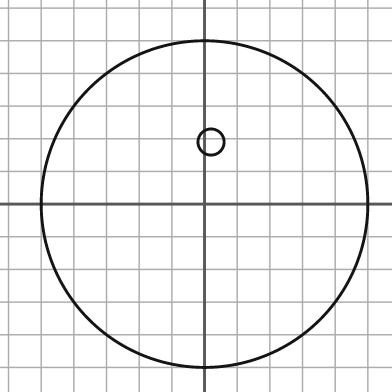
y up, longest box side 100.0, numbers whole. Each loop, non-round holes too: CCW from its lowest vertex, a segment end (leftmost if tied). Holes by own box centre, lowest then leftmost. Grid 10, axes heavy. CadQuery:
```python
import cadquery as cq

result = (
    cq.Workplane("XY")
    .moveTo(0.0, 0.0)
    .circle(50.0)
    .moveTo(2.0, 19.0)
    .circle(4.0)
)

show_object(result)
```